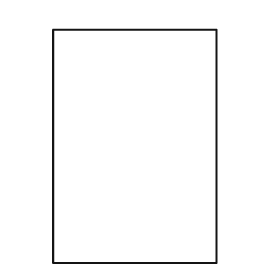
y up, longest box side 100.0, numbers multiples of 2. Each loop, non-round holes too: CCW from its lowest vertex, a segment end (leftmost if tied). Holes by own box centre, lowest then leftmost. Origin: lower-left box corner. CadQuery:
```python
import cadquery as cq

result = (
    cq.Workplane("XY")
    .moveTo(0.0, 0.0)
    .lineTo(70.0, 0.0)
    .lineTo(70.0, 100.0)
    .lineTo(0.0, 100.0)
    .close()
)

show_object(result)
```